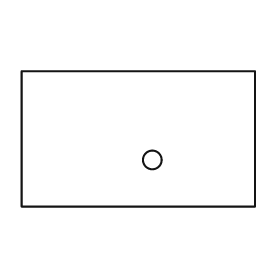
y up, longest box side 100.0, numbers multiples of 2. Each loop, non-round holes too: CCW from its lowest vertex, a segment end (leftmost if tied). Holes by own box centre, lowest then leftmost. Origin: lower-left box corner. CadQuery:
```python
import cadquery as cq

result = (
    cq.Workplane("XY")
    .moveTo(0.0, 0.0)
    .lineTo(100.0, 0.0)
    .lineTo(100.0, 58.0)
    .lineTo(0.0, 58.0)
    .close()
    .moveTo(56.0, 20.0)
    .circle(4.0)
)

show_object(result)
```